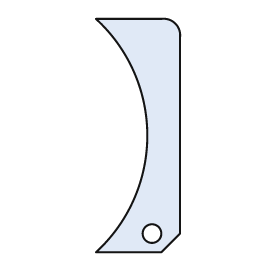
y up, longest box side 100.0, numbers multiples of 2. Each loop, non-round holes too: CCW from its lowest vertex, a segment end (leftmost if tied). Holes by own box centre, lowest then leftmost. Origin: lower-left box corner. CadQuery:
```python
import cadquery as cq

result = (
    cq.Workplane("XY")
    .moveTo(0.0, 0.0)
    .lineTo(28.0, 0.0)
    .lineTo(36.0, 8.0)
    .lineTo(36.0, 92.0)
    .threePointArc((34.0, 98.0), (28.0, 100.0))
    .lineTo(0.0, 100.0)
    .threePointArc((22.0, 50.0), (0.0, 0.0))
    .close()
    .moveTo(24.0, 8.0)
    .circle(4.0)
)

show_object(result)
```